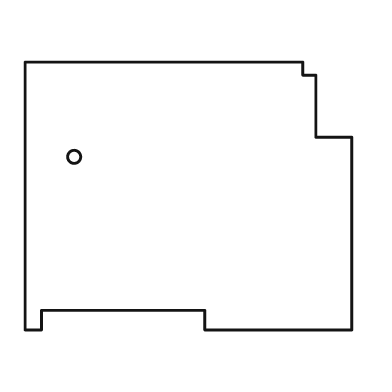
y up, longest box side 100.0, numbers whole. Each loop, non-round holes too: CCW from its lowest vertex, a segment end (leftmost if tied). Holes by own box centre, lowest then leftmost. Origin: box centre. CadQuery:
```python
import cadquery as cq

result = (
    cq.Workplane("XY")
    .moveTo(-50.0, -41.0)
    .lineTo(-45.0, -41.0)
    .lineTo(-45.0, -35.0)
    .lineTo(5.0, -35.0)
    .lineTo(5.0, -41.0)
    .lineTo(50.0, -41.0)
    .lineTo(50.0, 18.0)
    .lineTo(39.0, 18.0)
    .lineTo(39.0, 37.0)
    .lineTo(35.0, 37.0)
    .lineTo(35.0, 41.0)
    .lineTo(-50.0, 41.0)
    .close()
    .moveTo(-35.0, 12.0)
    .circle(2.0)
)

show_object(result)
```